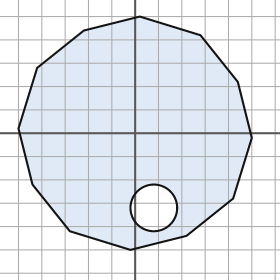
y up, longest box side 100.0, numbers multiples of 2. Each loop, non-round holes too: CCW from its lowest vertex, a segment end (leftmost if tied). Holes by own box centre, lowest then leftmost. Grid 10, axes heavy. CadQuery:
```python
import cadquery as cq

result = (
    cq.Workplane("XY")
    .moveTo(-2.0, -50.0)
    .lineTo(22.0, -44.0)
    .lineTo(42.0, -28.0)
    .lineTo(50.0, -2.0)
    .lineTo(44.0, 22.0)
    .lineTo(28.0, 42.0)
    .lineTo(2.0, 50.0)
    .lineTo(-22.0, 44.0)
    .lineTo(-42.0, 28.0)
    .lineTo(-50.0, 2.0)
    .lineTo(-44.0, -22.0)
    .lineTo(-28.0, -42.0)
    .close()
    .moveTo(8.0, -32.0)
    .circle(10.0)
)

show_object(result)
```